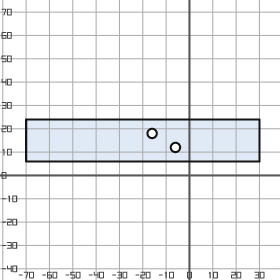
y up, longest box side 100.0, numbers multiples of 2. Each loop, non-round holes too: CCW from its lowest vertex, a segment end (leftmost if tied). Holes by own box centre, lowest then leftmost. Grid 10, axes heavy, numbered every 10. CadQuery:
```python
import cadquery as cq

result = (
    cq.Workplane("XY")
    .moveTo(-70.0, 6.0)
    .lineTo(30.0, 6.0)
    .lineTo(30.0, 24.0)
    .lineTo(-70.0, 24.0)
    .close()
    .moveTo(-6.0, 12.0)
    .circle(2.0)
    .moveTo(-16.0, 18.0)
    .circle(2.0)
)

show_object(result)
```